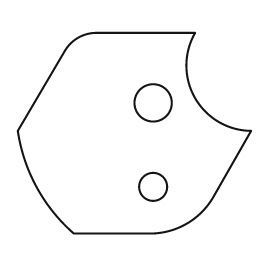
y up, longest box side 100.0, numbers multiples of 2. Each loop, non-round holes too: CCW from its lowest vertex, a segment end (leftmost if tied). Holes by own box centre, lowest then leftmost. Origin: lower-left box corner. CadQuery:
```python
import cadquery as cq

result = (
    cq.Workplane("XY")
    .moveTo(24.0, 0.0)
    .lineTo(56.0, 0.0)
    .threePointArc((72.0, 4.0), (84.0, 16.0))
    .lineTo(100.0, 44.0)
    .threePointArc((76.0, 58.0), (76.0, 86.0))
    .lineTo(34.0, 86.0)
    .threePointArc((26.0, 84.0), (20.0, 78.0))
    .lineTo(0.0, 44.0)
    .threePointArc((8.0, 20.0), (24.0, 0.0))
    .close()
    .moveTo(58.0, 20.0)
    .circle(6.0)
    .moveTo(58.0, 56.0)
    .circle(8.0)
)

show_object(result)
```